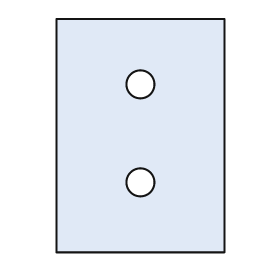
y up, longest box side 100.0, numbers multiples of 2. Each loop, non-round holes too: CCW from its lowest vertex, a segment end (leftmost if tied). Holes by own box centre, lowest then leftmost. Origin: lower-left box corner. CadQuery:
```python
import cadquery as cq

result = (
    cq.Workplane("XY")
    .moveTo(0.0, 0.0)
    .lineTo(72.0, 0.0)
    .lineTo(72.0, 100.0)
    .lineTo(0.0, 100.0)
    .close()
    .moveTo(36.0, 30.0)
    .circle(6.0)
    .moveTo(36.0, 72.0)
    .circle(6.0)
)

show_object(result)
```